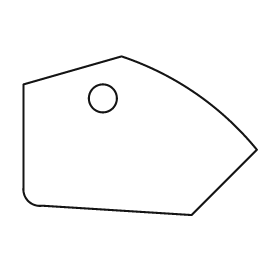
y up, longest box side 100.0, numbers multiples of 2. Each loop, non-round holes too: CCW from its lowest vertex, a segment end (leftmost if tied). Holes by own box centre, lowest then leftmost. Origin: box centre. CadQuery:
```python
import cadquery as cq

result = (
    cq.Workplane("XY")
    .moveTo(22.0, -34.0)
    .lineTo(50.0, -6.0)
    .threePointArc((24.0, 18.0), (-8.0, 34.0))
    .lineTo(-50.0, 22.0)
    .lineTo(-50.0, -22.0)
    .threePointArc((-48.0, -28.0), (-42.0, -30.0))
    .close()
    .moveTo(-16.0, 16.0)
    .circle(6.0)
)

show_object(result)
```